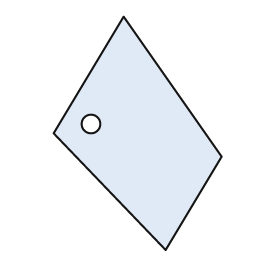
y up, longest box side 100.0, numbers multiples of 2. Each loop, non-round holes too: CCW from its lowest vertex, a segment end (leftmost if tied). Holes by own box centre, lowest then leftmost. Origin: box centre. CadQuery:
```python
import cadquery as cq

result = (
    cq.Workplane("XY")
    .moveTo(12.0, -50.0)
    .lineTo(36.0, -10.0)
    .lineTo(-6.0, 50.0)
    .lineTo(-36.0, 0.0)
    .close()
    .moveTo(-20.0, 4.0)
    .circle(4.0)
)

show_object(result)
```